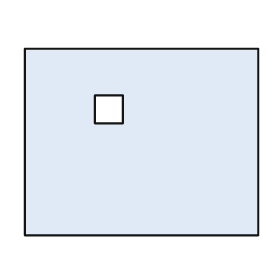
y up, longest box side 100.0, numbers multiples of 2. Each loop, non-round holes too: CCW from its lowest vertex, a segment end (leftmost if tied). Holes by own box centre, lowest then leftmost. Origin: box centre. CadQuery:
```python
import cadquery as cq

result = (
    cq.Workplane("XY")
    .moveTo(-50.0, -40.0)
    .lineTo(50.0, -40.0)
    .lineTo(50.0, 40.0)
    .lineTo(-50.0, 40.0)
    .close()
    .moveTo(-20.0, 8.0)
    .lineTo(-8.0, 8.0)
    .lineTo(-8.0, 20.0)
    .lineTo(-20.0, 20.0)
    .close()
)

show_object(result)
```